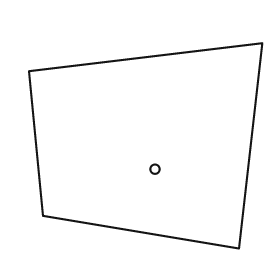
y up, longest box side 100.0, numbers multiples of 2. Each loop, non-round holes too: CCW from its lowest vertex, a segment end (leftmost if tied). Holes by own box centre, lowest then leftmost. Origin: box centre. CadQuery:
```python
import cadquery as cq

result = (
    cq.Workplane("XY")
    .moveTo(40.0, -44.0)
    .lineTo(50.0, 44.0)
    .lineTo(-50.0, 32.0)
    .lineTo(-44.0, -30.0)
    .close()
    .moveTo(4.0, -10.0)
    .circle(2.0)
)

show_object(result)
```